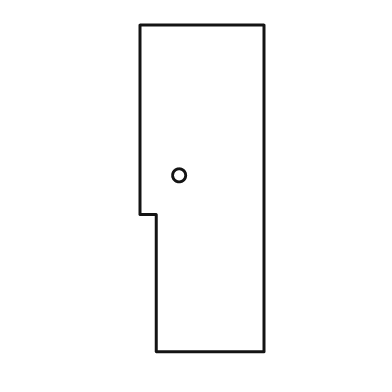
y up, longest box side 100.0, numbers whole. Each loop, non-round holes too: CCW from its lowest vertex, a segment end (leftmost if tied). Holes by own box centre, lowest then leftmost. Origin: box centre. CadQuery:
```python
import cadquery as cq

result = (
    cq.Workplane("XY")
    .moveTo(-14.0, -50.0)
    .lineTo(19.0, -50.0)
    .lineTo(19.0, 50.0)
    .lineTo(-19.0, 50.0)
    .lineTo(-19.0, -8.0)
    .lineTo(-14.0, -8.0)
    .close()
    .moveTo(-7.0, 4.0)
    .circle(2.0)
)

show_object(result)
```